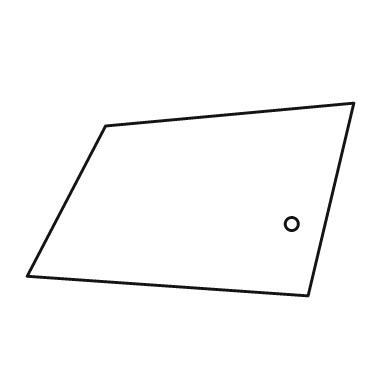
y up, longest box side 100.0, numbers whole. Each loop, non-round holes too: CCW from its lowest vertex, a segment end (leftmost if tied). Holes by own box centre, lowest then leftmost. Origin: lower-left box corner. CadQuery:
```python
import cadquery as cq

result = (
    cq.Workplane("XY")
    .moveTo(86.0, 0.0)
    .lineTo(100.0, 59.0)
    .lineTo(24.0, 52.0)
    .lineTo(0.0, 6.0)
    .close()
    .moveTo(81.0, 22.0)
    .circle(2.0)
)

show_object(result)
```